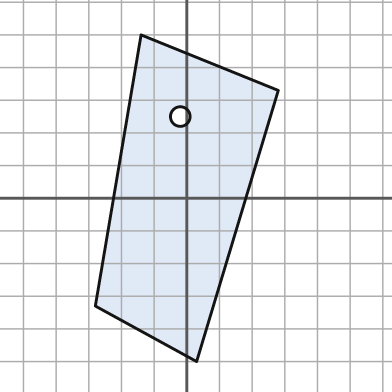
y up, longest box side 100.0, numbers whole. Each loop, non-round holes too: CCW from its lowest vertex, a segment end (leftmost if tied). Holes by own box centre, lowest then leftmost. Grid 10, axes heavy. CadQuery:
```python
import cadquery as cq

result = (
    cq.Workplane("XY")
    .moveTo(3.0, -50.0)
    .lineTo(28.0, 33.0)
    .lineTo(-14.0, 50.0)
    .lineTo(-28.0, -33.0)
    .close()
    .moveTo(-2.0, 25.0)
    .circle(3.0)
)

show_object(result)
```